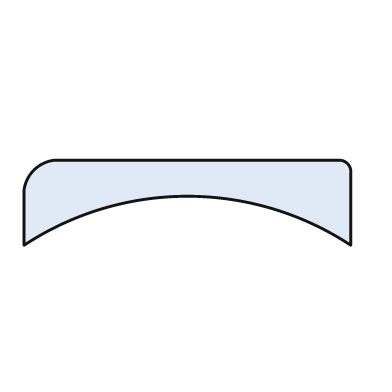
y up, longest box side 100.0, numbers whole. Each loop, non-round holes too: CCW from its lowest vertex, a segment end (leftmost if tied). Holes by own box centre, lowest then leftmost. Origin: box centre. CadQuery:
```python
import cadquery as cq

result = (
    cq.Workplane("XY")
    .moveTo(-50.0, -13.0)
    .threePointArc((0.0, 2.0), (50.0, -13.0))
    .lineTo(50.0, 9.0)
    .threePointArc((49.0, 12.0), (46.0, 13.0))
    .lineTo(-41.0, 13.0)
    .threePointArc((-47.0, 10.0), (-50.0, 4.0))
    .close()
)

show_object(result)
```